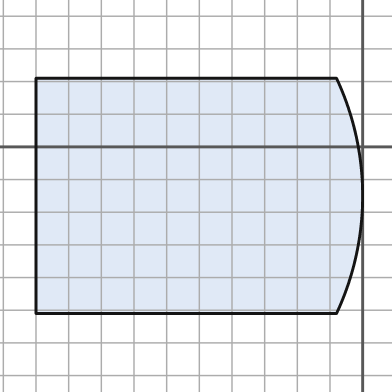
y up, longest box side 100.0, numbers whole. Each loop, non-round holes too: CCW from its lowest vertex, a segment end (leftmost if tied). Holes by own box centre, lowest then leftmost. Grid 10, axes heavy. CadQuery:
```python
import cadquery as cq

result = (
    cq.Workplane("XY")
    .moveTo(-100.0, -51.0)
    .lineTo(-8.0, -51.0)
    .threePointArc((0.0, -15.0), (-8.0, 21.0))
    .lineTo(-100.0, 21.0)
    .close()
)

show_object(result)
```